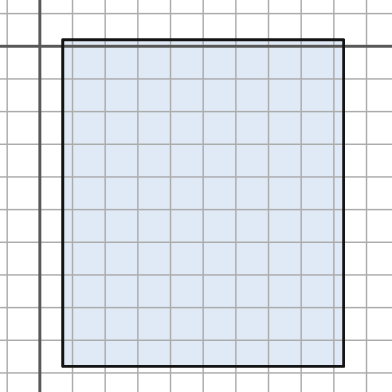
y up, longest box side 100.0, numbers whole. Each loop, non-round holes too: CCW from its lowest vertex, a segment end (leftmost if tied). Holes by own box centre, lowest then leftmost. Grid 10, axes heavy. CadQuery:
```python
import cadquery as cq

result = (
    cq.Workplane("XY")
    .moveTo(7.0, -98.0)
    .lineTo(93.0, -98.0)
    .lineTo(93.0, 2.0)
    .lineTo(7.0, 2.0)
    .close()
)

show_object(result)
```